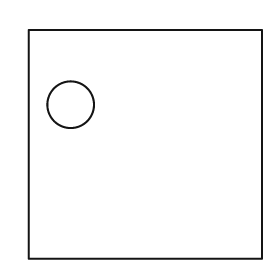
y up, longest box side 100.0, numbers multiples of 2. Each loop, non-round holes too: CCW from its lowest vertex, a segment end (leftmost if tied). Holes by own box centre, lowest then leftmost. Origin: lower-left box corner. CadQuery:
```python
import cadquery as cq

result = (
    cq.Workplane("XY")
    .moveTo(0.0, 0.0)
    .lineTo(100.0, 0.0)
    .lineTo(100.0, 98.0)
    .lineTo(0.0, 98.0)
    .close()
    .moveTo(18.0, 66.0)
    .circle(10.0)
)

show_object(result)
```